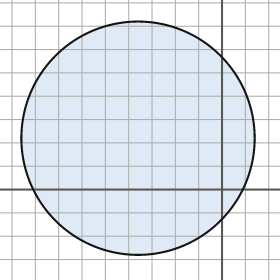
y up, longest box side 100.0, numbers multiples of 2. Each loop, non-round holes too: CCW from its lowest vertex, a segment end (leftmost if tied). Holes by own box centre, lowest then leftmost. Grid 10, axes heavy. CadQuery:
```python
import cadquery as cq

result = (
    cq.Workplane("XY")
    .moveTo(-36.0, 22.0)
    .circle(50.0)
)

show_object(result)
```